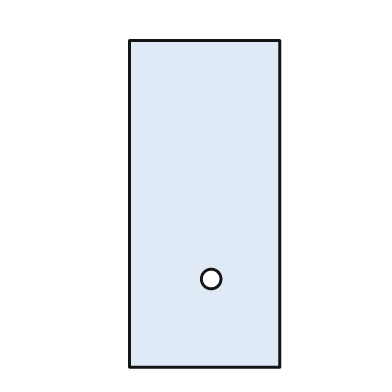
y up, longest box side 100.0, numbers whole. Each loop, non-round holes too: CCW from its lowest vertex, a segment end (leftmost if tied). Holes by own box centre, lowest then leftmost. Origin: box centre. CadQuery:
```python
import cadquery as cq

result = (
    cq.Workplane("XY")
    .moveTo(-23.0, -50.0)
    .lineTo(23.0, -50.0)
    .lineTo(23.0, 50.0)
    .lineTo(-23.0, 50.0)
    .close()
    .moveTo(2.0, -23.0)
    .circle(3.0)
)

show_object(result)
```